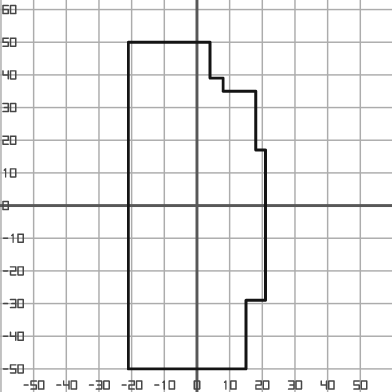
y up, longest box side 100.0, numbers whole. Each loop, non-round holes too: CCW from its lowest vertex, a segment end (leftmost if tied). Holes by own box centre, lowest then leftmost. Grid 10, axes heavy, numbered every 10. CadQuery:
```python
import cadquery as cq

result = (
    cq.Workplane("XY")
    .moveTo(-21.0, -50.0)
    .lineTo(15.0, -50.0)
    .lineTo(15.0, -29.0)
    .lineTo(21.0, -29.0)
    .lineTo(21.0, 17.0)
    .lineTo(18.0, 17.0)
    .lineTo(18.0, 35.0)
    .lineTo(8.0, 35.0)
    .lineTo(8.0, 39.0)
    .lineTo(4.0, 39.0)
    .lineTo(4.0, 50.0)
    .lineTo(-21.0, 50.0)
    .close()
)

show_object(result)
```